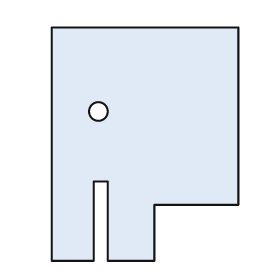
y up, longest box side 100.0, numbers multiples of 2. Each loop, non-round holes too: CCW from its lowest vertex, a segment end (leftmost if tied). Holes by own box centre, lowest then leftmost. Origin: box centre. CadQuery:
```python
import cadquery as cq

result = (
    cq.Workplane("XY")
    .moveTo(-40.0, -50.0)
    .lineTo(-22.0, -50.0)
    .lineTo(-22.0, -16.0)
    .lineTo(-16.0, -16.0)
    .lineTo(-16.0, -50.0)
    .lineTo(4.0, -50.0)
    .lineTo(4.0, -26.0)
    .lineTo(40.0, -26.0)
    .lineTo(40.0, 50.0)
    .lineTo(-40.0, 50.0)
    .close()
    .moveTo(-20.0, 14.0)
    .circle(4.0)
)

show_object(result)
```